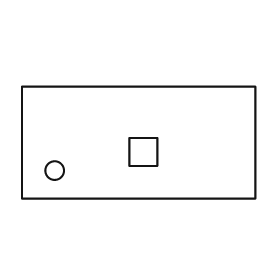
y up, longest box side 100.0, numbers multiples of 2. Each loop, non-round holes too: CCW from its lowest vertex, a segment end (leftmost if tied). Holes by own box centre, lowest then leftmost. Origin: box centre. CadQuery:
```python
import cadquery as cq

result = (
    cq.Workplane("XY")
    .moveTo(-50.0, -24.0)
    .lineTo(50.0, -24.0)
    .lineTo(50.0, 24.0)
    .lineTo(-50.0, 24.0)
    .close()
    .moveTo(-36.0, -12.0)
    .circle(4.0)
    .moveTo(-4.0, -10.0)
    .lineTo(8.0, -10.0)
    .lineTo(8.0, 2.0)
    .lineTo(-4.0, 2.0)
    .close()
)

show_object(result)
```